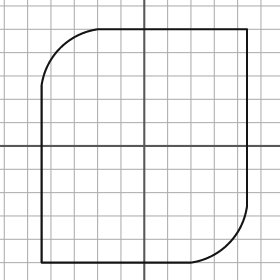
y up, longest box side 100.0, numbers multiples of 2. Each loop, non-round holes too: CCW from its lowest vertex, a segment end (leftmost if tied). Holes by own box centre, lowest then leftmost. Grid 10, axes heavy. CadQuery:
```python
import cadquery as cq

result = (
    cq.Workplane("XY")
    .moveTo(-44.0, -50.0)
    .lineTo(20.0, -50.0)
    .threePointArc((36.0, -42.0), (44.0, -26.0))
    .lineTo(44.0, 50.0)
    .lineTo(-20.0, 50.0)
    .threePointArc((-36.0, 42.0), (-44.0, 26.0))
    .close()
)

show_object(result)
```